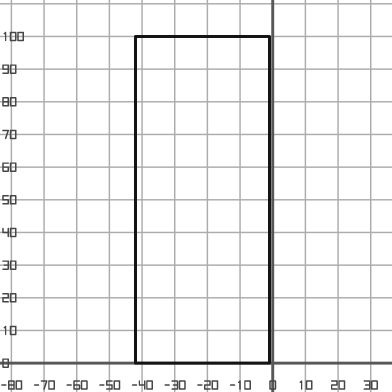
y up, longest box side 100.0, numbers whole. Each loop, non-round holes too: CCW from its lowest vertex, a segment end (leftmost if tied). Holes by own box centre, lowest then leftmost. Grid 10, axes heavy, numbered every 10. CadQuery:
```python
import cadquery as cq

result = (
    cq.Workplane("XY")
    .moveTo(-42.0, 0.0)
    .lineTo(-1.0, 0.0)
    .lineTo(-1.0, 100.0)
    .lineTo(-42.0, 100.0)
    .close()
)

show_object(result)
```